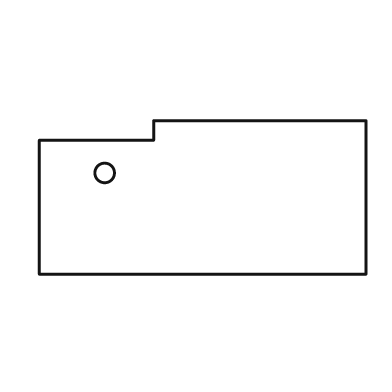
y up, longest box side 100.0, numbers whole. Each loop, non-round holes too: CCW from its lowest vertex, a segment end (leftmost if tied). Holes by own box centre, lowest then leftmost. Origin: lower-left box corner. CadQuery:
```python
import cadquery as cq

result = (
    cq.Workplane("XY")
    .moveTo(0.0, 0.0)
    .lineTo(100.0, 0.0)
    .lineTo(100.0, 47.0)
    .lineTo(35.0, 47.0)
    .lineTo(35.0, 41.0)
    .lineTo(0.0, 41.0)
    .close()
    .moveTo(20.0, 31.0)
    .circle(3.0)
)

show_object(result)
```